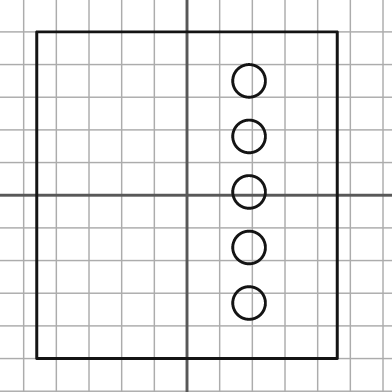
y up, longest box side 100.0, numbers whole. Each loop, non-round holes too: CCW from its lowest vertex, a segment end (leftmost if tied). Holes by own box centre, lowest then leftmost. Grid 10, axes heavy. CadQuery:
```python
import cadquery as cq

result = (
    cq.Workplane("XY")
    .moveTo(-46.0, -50.0)
    .lineTo(46.0, -50.0)
    .lineTo(46.0, 50.0)
    .lineTo(-46.0, 50.0)
    .close()
    .moveTo(19.0, -33.0)
    .circle(5.0)
    .moveTo(19.0, -16.0)
    .circle(5.0)
    .moveTo(19.0, 1.0)
    .circle(5.0)
    .moveTo(19.0, 18.0)
    .circle(5.0)
    .moveTo(19.0, 35.0)
    .circle(5.0)
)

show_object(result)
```